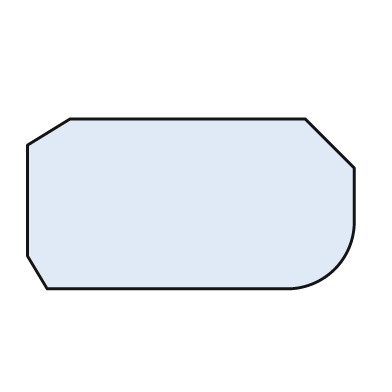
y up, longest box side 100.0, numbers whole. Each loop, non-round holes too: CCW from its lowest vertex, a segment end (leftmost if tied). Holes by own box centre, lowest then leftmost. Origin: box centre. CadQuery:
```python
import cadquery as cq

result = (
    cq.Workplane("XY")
    .moveTo(-44.0, -26.0)
    .lineTo(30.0, -26.0)
    .threePointArc((44.0, -20.0), (50.0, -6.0))
    .lineTo(50.0, 11.0)
    .lineTo(35.0, 26.0)
    .lineTo(-37.0, 26.0)
    .lineTo(-50.0, 18.0)
    .lineTo(-50.0, -16.0)
    .close()
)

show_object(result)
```